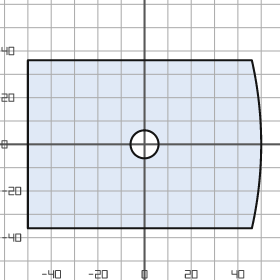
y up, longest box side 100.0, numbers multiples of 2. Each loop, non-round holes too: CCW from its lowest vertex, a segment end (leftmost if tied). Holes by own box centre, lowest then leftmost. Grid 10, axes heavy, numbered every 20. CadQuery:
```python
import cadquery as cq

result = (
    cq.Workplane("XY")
    .moveTo(-50.0, -36.0)
    .lineTo(46.0, -36.0)
    .threePointArc((50.0, 0.0), (46.0, 36.0))
    .lineTo(-50.0, 36.0)
    .close()
    .moveTo(0.0, 0.0)
    .circle(6.0)
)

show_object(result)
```